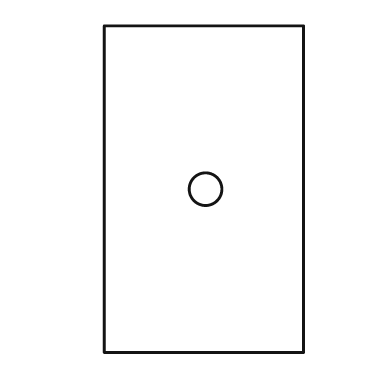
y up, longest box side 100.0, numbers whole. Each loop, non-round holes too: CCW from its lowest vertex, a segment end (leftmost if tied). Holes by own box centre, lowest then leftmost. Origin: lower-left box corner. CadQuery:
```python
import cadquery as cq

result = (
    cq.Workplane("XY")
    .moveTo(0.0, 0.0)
    .lineTo(61.0, 0.0)
    .lineTo(61.0, 100.0)
    .lineTo(0.0, 100.0)
    .close()
    .moveTo(31.0, 50.0)
    .circle(5.0)
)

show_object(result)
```